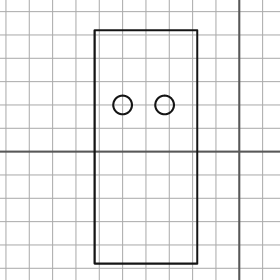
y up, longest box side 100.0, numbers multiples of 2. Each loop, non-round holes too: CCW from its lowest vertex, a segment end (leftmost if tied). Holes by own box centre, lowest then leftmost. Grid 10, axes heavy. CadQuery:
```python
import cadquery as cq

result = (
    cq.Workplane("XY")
    .moveTo(-62.0, -48.0)
    .lineTo(-18.0, -48.0)
    .lineTo(-18.0, 52.0)
    .lineTo(-62.0, 52.0)
    .close()
    .moveTo(-50.0, 20.0)
    .circle(4.0)
    .moveTo(-32.0, 20.0)
    .circle(4.0)
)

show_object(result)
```